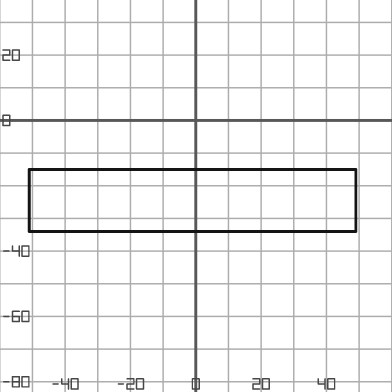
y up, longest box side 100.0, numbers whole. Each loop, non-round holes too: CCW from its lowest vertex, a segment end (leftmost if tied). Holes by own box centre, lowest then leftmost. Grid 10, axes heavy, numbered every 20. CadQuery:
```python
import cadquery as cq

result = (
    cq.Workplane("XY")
    .moveTo(-51.0, -34.0)
    .lineTo(49.0, -34.0)
    .lineTo(49.0, -15.0)
    .lineTo(-51.0, -15.0)
    .close()
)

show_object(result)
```